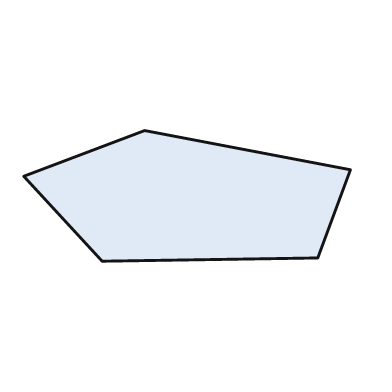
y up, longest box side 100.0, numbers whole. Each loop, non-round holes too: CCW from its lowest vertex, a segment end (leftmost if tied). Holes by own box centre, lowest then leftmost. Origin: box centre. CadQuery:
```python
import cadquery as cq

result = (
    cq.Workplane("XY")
    .moveTo(-26.0, -20.0)
    .lineTo(40.0, -19.0)
    .lineTo(50.0, 8.0)
    .lineTo(-13.0, 20.0)
    .lineTo(-50.0, 6.0)
    .close()
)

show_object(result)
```